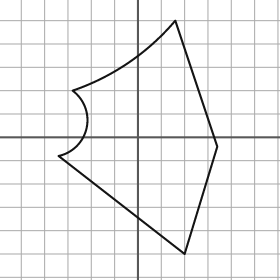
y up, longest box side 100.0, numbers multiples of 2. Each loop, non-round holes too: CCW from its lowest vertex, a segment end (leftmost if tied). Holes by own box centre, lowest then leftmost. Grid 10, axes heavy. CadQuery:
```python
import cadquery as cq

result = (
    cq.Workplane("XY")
    .moveTo(20.0, -50.0)
    .lineTo(34.0, -4.0)
    .lineTo(16.0, 50.0)
    .threePointArc((-4.0, 32.0), (-28.0, 20.0))
    .threePointArc((-22.0, 4.0), (-34.0, -8.0))
    .close()
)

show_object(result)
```